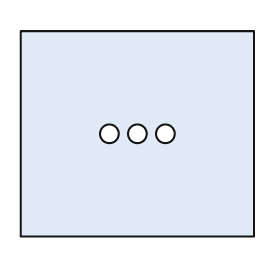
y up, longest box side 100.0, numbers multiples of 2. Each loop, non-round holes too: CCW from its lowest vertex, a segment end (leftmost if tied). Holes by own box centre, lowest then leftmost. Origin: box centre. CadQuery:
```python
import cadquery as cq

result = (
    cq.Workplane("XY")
    .moveTo(-50.0, -44.0)
    .lineTo(50.0, -44.0)
    .lineTo(50.0, 44.0)
    .lineTo(-50.0, 44.0)
    .close()
    .moveTo(-12.0, 0.0)
    .circle(4.0)
    .moveTo(0.0, 0.0)
    .circle(4.0)
    .moveTo(12.0, 0.0)
    .circle(4.0)
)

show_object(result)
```